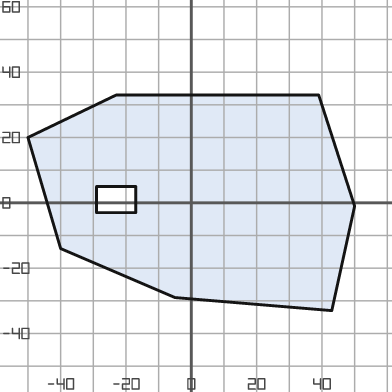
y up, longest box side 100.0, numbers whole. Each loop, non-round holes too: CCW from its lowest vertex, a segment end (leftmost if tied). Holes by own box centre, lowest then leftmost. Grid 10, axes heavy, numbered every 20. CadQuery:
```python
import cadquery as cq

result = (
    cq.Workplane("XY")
    .moveTo(43.0, -33.0)
    .lineTo(50.0, -1.0)
    .lineTo(39.0, 33.0)
    .lineTo(-23.0, 33.0)
    .lineTo(-50.0, 20.0)
    .lineTo(-40.0, -14.0)
    .lineTo(-5.0, -29.0)
    .close()
    .moveTo(-29.0, -3.0)
    .lineTo(-17.0, -3.0)
    .lineTo(-17.0, 5.0)
    .lineTo(-29.0, 5.0)
    .close()
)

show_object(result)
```